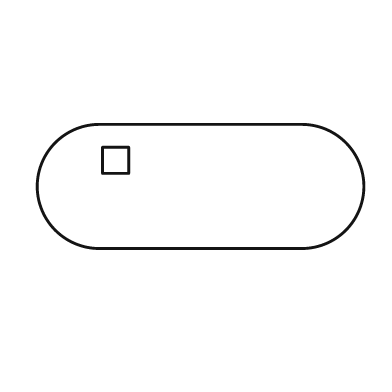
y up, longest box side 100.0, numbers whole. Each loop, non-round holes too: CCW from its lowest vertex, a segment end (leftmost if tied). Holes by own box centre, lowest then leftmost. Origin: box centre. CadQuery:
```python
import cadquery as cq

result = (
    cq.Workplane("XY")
    .moveTo(-31.0, -19.0)
    .lineTo(31.0, -19.0)
    .threePointArc((50.0, 0.0), (31.0, 19.0))
    .lineTo(-31.0, 19.0)
    .threePointArc((-50.0, 0.0), (-31.0, -19.0))
    .close()
    .moveTo(-30.0, 4.0)
    .lineTo(-22.0, 4.0)
    .lineTo(-22.0, 12.0)
    .lineTo(-30.0, 12.0)
    .close()
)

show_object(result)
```